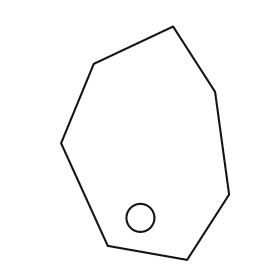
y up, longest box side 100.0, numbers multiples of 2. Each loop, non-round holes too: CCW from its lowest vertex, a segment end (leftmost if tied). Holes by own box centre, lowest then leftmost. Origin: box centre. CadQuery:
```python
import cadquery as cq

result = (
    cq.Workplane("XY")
    .moveTo(18.0, -50.0)
    .lineTo(36.0, -22.0)
    .lineTo(30.0, 22.0)
    .lineTo(12.0, 50.0)
    .lineTo(-22.0, 34.0)
    .lineTo(-36.0, 0.0)
    .lineTo(-16.0, -44.0)
    .close()
    .moveTo(-2.0, -32.0)
    .circle(6.0)
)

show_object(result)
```